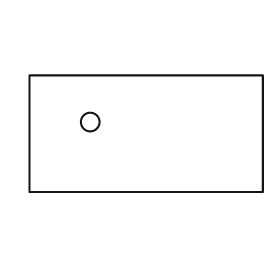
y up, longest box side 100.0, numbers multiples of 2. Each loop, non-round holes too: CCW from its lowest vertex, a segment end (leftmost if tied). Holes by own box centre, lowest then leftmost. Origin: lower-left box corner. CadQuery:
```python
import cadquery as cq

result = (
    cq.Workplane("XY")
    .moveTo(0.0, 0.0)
    .lineTo(100.0, 0.0)
    .lineTo(100.0, 50.0)
    .lineTo(0.0, 50.0)
    .close()
    .moveTo(26.0, 30.0)
    .circle(4.0)
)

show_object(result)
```